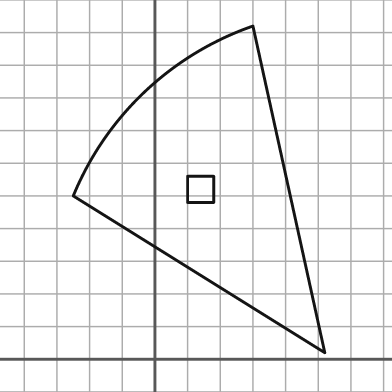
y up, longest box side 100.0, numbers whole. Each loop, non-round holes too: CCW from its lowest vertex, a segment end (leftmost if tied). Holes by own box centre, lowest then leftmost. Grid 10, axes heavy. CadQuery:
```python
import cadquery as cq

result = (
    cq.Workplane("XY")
    .moveTo(52.0, 2.0)
    .lineTo(30.0, 102.0)
    .threePointArc((-3.0, 82.0), (-25.0, 50.0))
    .close()
    .moveTo(10.0, 48.0)
    .lineTo(18.0, 48.0)
    .lineTo(18.0, 56.0)
    .lineTo(10.0, 56.0)
    .close()
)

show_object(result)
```